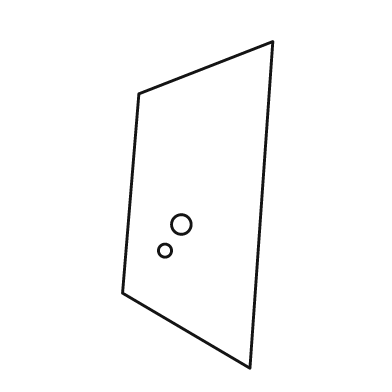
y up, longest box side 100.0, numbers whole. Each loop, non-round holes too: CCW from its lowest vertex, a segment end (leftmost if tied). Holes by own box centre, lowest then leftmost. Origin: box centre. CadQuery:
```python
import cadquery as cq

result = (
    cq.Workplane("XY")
    .moveTo(16.0, -50.0)
    .lineTo(23.0, 50.0)
    .lineTo(-18.0, 34.0)
    .lineTo(-23.0, -27.0)
    .close()
    .moveTo(-10.0, -14.0)
    .circle(2.0)
    .moveTo(-5.0, -6.0)
    .circle(3.0)
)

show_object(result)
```